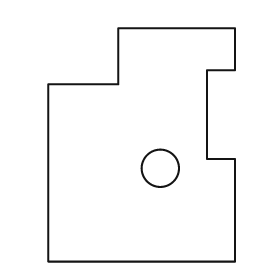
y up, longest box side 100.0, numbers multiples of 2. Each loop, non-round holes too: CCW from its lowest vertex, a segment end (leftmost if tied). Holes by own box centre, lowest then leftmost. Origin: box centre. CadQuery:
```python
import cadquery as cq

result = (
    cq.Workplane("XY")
    .moveTo(-40.0, -50.0)
    .lineTo(40.0, -50.0)
    .lineTo(40.0, -6.0)
    .lineTo(28.0, -6.0)
    .lineTo(28.0, 32.0)
    .lineTo(40.0, 32.0)
    .lineTo(40.0, 50.0)
    .lineTo(-10.0, 50.0)
    .lineTo(-10.0, 26.0)
    .lineTo(-40.0, 26.0)
    .close()
    .moveTo(8.0, -10.0)
    .circle(8.0)
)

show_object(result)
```